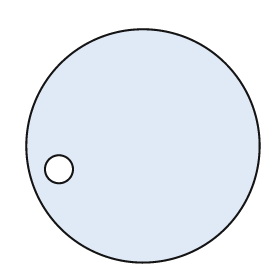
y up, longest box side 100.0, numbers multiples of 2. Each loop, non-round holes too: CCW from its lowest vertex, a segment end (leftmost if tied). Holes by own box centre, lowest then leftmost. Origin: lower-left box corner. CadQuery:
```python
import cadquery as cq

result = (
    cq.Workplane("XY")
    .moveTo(50.0, 50.0)
    .circle(50.0)
    .moveTo(14.0, 40.0)
    .circle(6.0)
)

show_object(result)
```